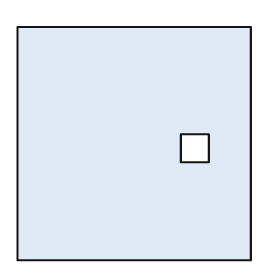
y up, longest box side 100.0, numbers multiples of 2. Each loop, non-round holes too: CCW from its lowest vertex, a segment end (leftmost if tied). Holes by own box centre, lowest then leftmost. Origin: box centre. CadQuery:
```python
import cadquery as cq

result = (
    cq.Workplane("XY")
    .moveTo(-50.0, -50.0)
    .lineTo(50.0, -50.0)
    .lineTo(50.0, 50.0)
    .lineTo(-50.0, 50.0)
    .close()
    .moveTo(20.0, -8.0)
    .lineTo(32.0, -8.0)
    .lineTo(32.0, 4.0)
    .lineTo(20.0, 4.0)
    .close()
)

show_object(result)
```